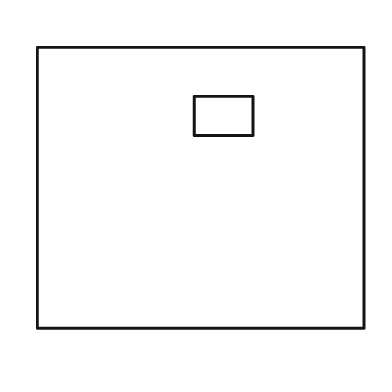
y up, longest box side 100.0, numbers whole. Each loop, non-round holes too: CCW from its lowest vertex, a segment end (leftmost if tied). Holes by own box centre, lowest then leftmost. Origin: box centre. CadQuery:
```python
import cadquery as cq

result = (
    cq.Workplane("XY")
    .moveTo(-50.0, -43.0)
    .lineTo(50.0, -43.0)
    .lineTo(50.0, 43.0)
    .lineTo(-50.0, 43.0)
    .close()
    .moveTo(-2.0, 16.0)
    .lineTo(16.0, 16.0)
    .lineTo(16.0, 28.0)
    .lineTo(-2.0, 28.0)
    .close()
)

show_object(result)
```